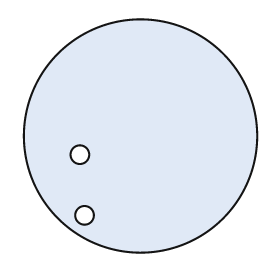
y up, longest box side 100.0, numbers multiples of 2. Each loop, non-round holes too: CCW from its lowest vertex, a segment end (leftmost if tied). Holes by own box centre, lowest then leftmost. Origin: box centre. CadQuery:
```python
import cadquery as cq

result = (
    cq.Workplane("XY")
    .moveTo(0.0, 0.0)
    .circle(50.0)
    .moveTo(-24.0, -34.0)
    .circle(4.0)
    .moveTo(-26.0, -8.0)
    .circle(4.0)
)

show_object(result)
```